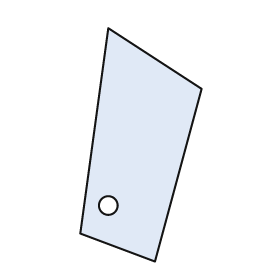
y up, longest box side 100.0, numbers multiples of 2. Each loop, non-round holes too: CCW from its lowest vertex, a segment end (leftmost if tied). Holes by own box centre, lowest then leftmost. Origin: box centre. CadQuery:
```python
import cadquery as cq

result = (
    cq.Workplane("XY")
    .moveTo(6.0, -50.0)
    .lineTo(26.0, 24.0)
    .lineTo(-14.0, 50.0)
    .lineTo(-26.0, -38.0)
    .close()
    .moveTo(-14.0, -26.0)
    .circle(4.0)
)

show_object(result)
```